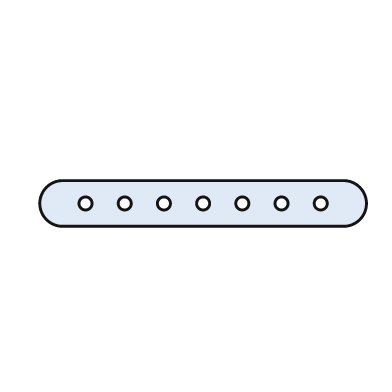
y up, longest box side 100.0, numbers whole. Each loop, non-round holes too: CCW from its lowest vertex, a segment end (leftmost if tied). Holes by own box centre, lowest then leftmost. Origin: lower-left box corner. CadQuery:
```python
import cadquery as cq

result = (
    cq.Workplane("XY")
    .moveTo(7.0, 0.0)
    .lineTo(93.0, 0.0)
    .threePointArc((100.0, 7.0), (93.0, 14.0))
    .lineTo(7.0, 14.0)
    .threePointArc((0.0, 7.0), (7.0, 0.0))
    .close()
    .moveTo(14.0, 7.0)
    .circle(2.0)
    .moveTo(26.0, 7.0)
    .circle(2.0)
    .moveTo(38.0, 7.0)
    .circle(2.0)
    .moveTo(50.0, 7.0)
    .circle(2.0)
    .moveTo(62.0, 7.0)
    .circle(2.0)
    .moveTo(74.0, 7.0)
    .circle(2.0)
    .moveTo(86.0, 7.0)
    .circle(2.0)
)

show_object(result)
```